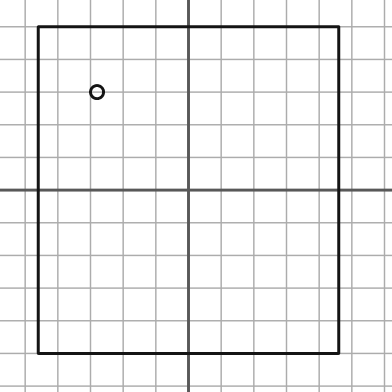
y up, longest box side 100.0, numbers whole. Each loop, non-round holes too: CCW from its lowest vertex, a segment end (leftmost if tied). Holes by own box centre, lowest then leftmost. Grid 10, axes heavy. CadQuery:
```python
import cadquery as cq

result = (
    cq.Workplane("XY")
    .moveTo(-46.0, -50.0)
    .lineTo(46.0, -50.0)
    .lineTo(46.0, 50.0)
    .lineTo(-46.0, 50.0)
    .close()
    .moveTo(-28.0, 30.0)
    .circle(2.0)
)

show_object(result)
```